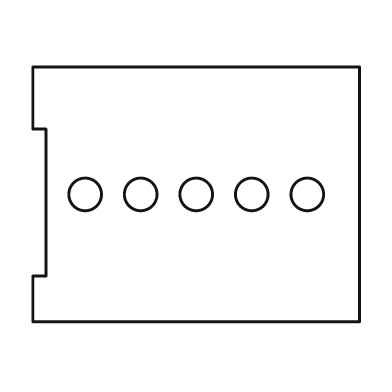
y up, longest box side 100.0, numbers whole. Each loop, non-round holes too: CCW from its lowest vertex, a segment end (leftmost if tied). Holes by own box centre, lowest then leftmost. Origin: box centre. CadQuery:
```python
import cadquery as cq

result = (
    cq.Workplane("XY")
    .moveTo(-50.0, -39.0)
    .lineTo(50.0, -39.0)
    .lineTo(50.0, 39.0)
    .lineTo(-50.0, 39.0)
    .lineTo(-50.0, 20.0)
    .lineTo(-46.0, 20.0)
    .lineTo(-46.0, -25.0)
    .lineTo(-50.0, -25.0)
    .close()
    .moveTo(-34.0, 0.0)
    .circle(5.0)
    .moveTo(-17.0, 0.0)
    .circle(5.0)
    .moveTo(0.0, 0.0)
    .circle(5.0)
    .moveTo(17.0, 0.0)
    .circle(5.0)
    .moveTo(34.0, 0.0)
    .circle(5.0)
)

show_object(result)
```